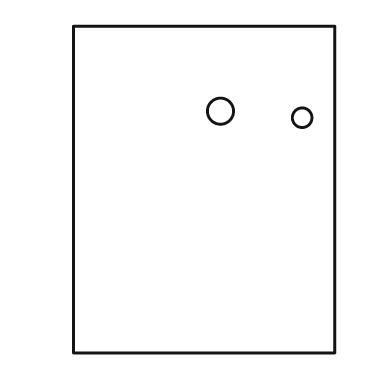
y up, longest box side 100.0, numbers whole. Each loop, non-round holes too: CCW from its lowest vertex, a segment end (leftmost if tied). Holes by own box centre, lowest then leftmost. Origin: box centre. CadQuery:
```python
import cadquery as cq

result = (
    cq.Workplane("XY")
    .moveTo(-40.0, -50.0)
    .lineTo(40.0, -50.0)
    .lineTo(40.0, 50.0)
    .lineTo(-40.0, 50.0)
    .close()
    .moveTo(30.0, 22.0)
    .circle(3.0)
    .moveTo(5.0, 24.0)
    .circle(4.0)
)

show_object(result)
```